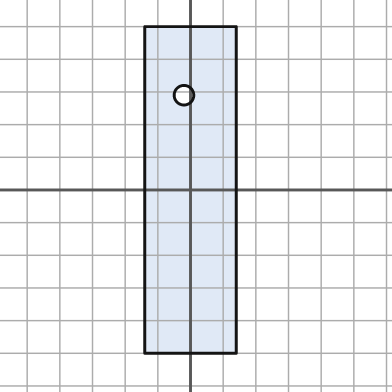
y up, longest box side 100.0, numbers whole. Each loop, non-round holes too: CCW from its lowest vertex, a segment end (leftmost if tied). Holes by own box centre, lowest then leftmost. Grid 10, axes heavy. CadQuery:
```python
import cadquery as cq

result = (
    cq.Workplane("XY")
    .moveTo(-14.0, -50.0)
    .lineTo(14.0, -50.0)
    .lineTo(14.0, 50.0)
    .lineTo(-14.0, 50.0)
    .close()
    .moveTo(-2.0, 29.0)
    .circle(3.0)
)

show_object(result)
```